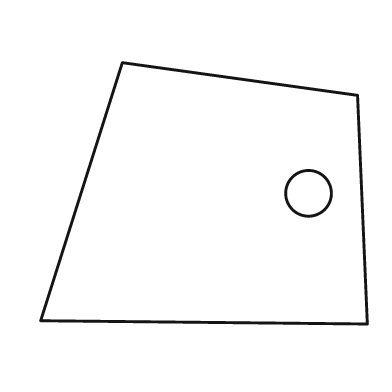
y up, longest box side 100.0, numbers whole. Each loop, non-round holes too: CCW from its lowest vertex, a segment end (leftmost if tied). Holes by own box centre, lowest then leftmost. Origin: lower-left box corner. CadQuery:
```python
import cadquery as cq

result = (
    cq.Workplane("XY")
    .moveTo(100.0, 0.0)
    .lineTo(97.0, 70.0)
    .lineTo(25.0, 80.0)
    .lineTo(0.0, 1.0)
    .close()
    .moveTo(82.0, 40.0)
    .circle(7.0)
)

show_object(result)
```